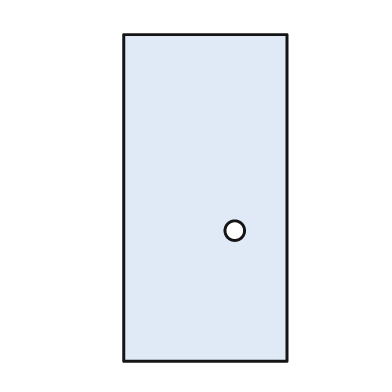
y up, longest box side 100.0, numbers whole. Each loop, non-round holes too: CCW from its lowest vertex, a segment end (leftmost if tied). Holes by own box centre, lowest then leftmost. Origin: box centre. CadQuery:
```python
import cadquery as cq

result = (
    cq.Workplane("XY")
    .moveTo(-25.0, -50.0)
    .lineTo(25.0, -50.0)
    .lineTo(25.0, 50.0)
    .lineTo(-25.0, 50.0)
    .close()
    .moveTo(9.0, -10.0)
    .circle(3.0)
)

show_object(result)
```